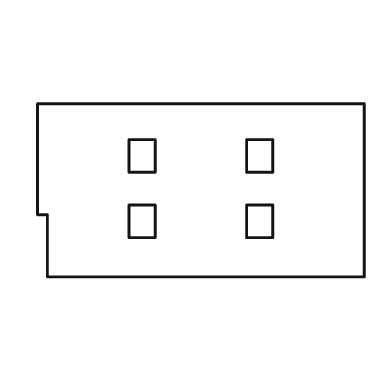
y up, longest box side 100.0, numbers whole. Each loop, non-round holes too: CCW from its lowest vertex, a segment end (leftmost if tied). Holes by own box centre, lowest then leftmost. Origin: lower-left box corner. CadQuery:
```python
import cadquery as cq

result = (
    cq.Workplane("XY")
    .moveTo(3.0, 0.0)
    .lineTo(100.0, 0.0)
    .lineTo(100.0, 53.0)
    .lineTo(0.0, 53.0)
    .lineTo(0.0, 19.0)
    .lineTo(3.0, 19.0)
    .close()
    .moveTo(28.0, 12.0)
    .lineTo(36.0, 12.0)
    .lineTo(36.0, 22.0)
    .lineTo(28.0, 22.0)
    .close()
    .moveTo(64.0, 12.0)
    .lineTo(72.0, 12.0)
    .lineTo(72.0, 22.0)
    .lineTo(64.0, 22.0)
    .close()
    .moveTo(28.0, 32.0)
    .lineTo(36.0, 32.0)
    .lineTo(36.0, 42.0)
    .lineTo(28.0, 42.0)
    .close()
    .moveTo(64.0, 32.0)
    .lineTo(72.0, 32.0)
    .lineTo(72.0, 42.0)
    .lineTo(64.0, 42.0)
    .close()
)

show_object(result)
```